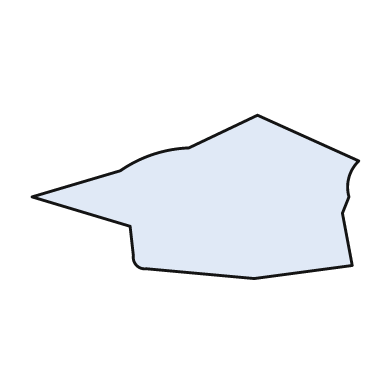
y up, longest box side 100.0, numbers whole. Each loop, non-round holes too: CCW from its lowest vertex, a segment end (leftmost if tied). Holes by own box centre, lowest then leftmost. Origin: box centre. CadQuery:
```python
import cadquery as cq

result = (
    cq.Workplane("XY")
    .moveTo(18.0, -25.0)
    .lineTo(48.0, -21.0)
    .lineTo(45.0, -5.0)
    .lineTo(47.0, 0.0)
    .threePointArc((47.0, 6.0), (50.0, 11.0))
    .lineTo(19.0, 25.0)
    .lineTo(-2.0, 15.0)
    .threePointArc((-13.0, 13.0), (-23.0, 8.0))
    .lineTo(-50.0, 0.0)
    .lineTo(-20.0, -9.0)
    .lineTo(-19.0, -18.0)
    .threePointArc((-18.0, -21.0), (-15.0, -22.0))
    .close()
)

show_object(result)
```